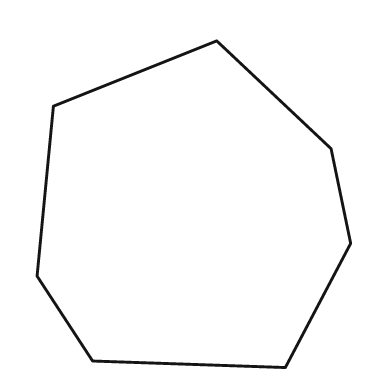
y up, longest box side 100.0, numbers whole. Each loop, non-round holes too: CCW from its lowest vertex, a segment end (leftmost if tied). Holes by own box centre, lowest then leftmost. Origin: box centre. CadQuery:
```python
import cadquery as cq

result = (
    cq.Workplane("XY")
    .moveTo(28.0, -50.0)
    .lineTo(48.0, -12.0)
    .lineTo(42.0, 17.0)
    .lineTo(7.0, 50.0)
    .lineTo(-43.0, 30.0)
    .lineTo(-48.0, -22.0)
    .lineTo(-31.0, -48.0)
    .close()
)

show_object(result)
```